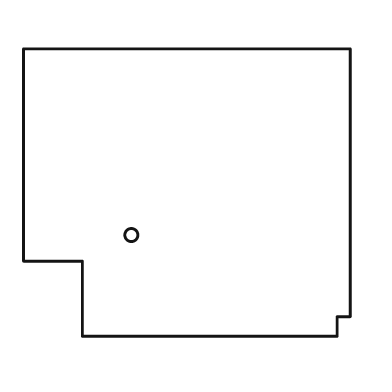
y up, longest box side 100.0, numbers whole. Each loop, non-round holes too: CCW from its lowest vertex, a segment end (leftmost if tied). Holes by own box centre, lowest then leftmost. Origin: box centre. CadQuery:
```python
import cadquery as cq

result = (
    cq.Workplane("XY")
    .moveTo(-32.0, -44.0)
    .lineTo(46.0, -44.0)
    .lineTo(46.0, -38.0)
    .lineTo(50.0, -38.0)
    .lineTo(50.0, 44.0)
    .lineTo(-50.0, 44.0)
    .lineTo(-50.0, -21.0)
    .lineTo(-32.0, -21.0)
    .close()
    .moveTo(-17.0, -13.0)
    .circle(2.0)
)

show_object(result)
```